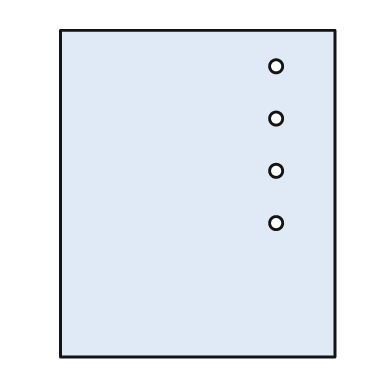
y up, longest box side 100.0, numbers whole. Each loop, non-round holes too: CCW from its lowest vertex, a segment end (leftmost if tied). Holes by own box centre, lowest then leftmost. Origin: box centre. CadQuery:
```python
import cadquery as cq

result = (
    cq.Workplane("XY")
    .moveTo(-42.0, -50.0)
    .lineTo(42.0, -50.0)
    .lineTo(42.0, 50.0)
    .lineTo(-42.0, 50.0)
    .close()
    .moveTo(24.0, -9.0)
    .circle(2.0)
    .moveTo(24.0, 7.0)
    .circle(2.0)
    .moveTo(24.0, 23.0)
    .circle(2.0)
    .moveTo(24.0, 39.0)
    .circle(2.0)
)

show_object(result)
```